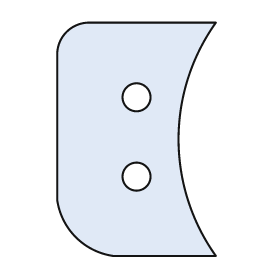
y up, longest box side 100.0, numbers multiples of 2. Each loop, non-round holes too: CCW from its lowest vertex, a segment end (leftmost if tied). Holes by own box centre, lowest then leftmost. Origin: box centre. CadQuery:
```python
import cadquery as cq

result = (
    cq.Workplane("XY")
    .moveTo(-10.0, -50.0)
    .lineTo(34.0, -50.0)
    .threePointArc((18.0, 0.0), (34.0, 50.0))
    .lineTo(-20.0, 50.0)
    .threePointArc((-30.0, 46.0), (-34.0, 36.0))
    .lineTo(-34.0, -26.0)
    .threePointArc((-26.0, -42.0), (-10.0, -50.0))
    .close()
    .moveTo(0.0, -16.0)
    .circle(6.0)
    .moveTo(0.0, 18.0)
    .circle(6.0)
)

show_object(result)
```